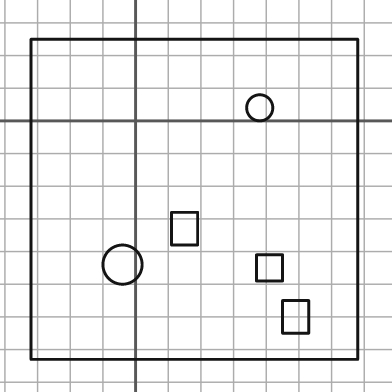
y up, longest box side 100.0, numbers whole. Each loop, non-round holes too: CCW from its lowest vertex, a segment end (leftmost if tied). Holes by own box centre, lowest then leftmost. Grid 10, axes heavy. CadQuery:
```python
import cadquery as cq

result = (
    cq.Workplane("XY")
    .moveTo(-32.0, -73.0)
    .lineTo(68.0, -73.0)
    .lineTo(68.0, 25.0)
    .lineTo(-32.0, 25.0)
    .close()
    .moveTo(45.0, -65.0)
    .lineTo(53.0, -65.0)
    .lineTo(53.0, -55.0)
    .lineTo(45.0, -55.0)
    .close()
    .moveTo(37.0, -49.0)
    .lineTo(45.0, -49.0)
    .lineTo(45.0, -41.0)
    .lineTo(37.0, -41.0)
    .close()
    .moveTo(-4.0, -44.0)
    .circle(6.0)
    .moveTo(11.0, -38.0)
    .lineTo(19.0, -38.0)
    .lineTo(19.0, -28.0)
    .lineTo(11.0, -28.0)
    .close()
    .moveTo(38.0, 4.0)
    .circle(4.0)
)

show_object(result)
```